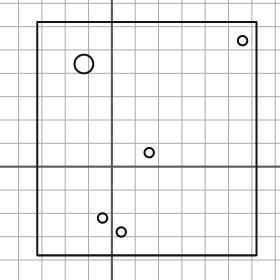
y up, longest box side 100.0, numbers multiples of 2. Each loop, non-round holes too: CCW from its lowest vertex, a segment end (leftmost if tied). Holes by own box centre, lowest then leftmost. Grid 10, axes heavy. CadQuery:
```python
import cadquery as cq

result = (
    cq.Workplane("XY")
    .moveTo(-32.0, -38.0)
    .lineTo(62.0, -38.0)
    .lineTo(62.0, 62.0)
    .lineTo(-32.0, 62.0)
    .close()
    .moveTo(4.0, -28.0)
    .circle(2.0)
    .moveTo(-4.0, -22.0)
    .circle(2.0)
    .moveTo(16.0, 6.0)
    .circle(2.0)
    .moveTo(-12.0, 44.0)
    .circle(4.0)
    .moveTo(56.0, 54.0)
    .circle(2.0)
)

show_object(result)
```